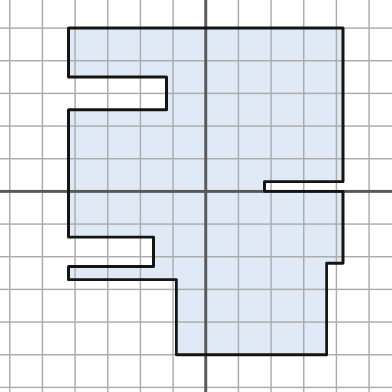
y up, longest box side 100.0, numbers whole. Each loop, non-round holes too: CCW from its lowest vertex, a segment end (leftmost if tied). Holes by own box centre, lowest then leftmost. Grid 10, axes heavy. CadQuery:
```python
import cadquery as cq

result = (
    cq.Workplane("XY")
    .moveTo(-9.0, -50.0)
    .lineTo(37.0, -50.0)
    .lineTo(37.0, -22.0)
    .lineTo(42.0, -22.0)
    .lineTo(42.0, 0.0)
    .lineTo(18.0, 0.0)
    .lineTo(18.0, 3.0)
    .lineTo(42.0, 3.0)
    .lineTo(42.0, 50.0)
    .lineTo(-42.0, 50.0)
    .lineTo(-42.0, 35.0)
    .lineTo(-12.0, 35.0)
    .lineTo(-12.0, 25.0)
    .lineTo(-42.0, 25.0)
    .lineTo(-42.0, -14.0)
    .lineTo(-16.0, -14.0)
    .lineTo(-16.0, -23.0)
    .lineTo(-42.0, -23.0)
    .lineTo(-42.0, -27.0)
    .lineTo(-9.0, -27.0)
    .close()
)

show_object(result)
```